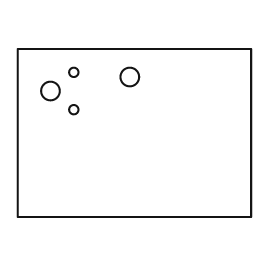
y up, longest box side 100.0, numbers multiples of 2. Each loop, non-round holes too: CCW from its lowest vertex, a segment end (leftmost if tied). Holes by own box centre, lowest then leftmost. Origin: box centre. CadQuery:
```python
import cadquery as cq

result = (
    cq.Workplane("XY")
    .moveTo(-50.0, -36.0)
    .lineTo(50.0, -36.0)
    .lineTo(50.0, 36.0)
    .lineTo(-50.0, 36.0)
    .close()
    .moveTo(-26.0, 10.0)
    .circle(2.0)
    .moveTo(-36.0, 18.0)
    .circle(4.0)
    .moveTo(-2.0, 24.0)
    .circle(4.0)
    .moveTo(-26.0, 26.0)
    .circle(2.0)
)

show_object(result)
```